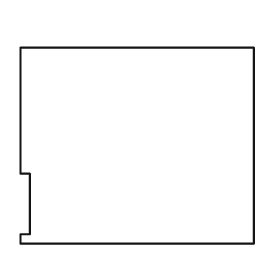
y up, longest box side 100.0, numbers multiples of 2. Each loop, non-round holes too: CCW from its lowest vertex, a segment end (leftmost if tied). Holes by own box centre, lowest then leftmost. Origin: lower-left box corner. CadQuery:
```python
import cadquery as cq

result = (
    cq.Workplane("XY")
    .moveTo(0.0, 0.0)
    .lineTo(100.0, 0.0)
    .lineTo(100.0, 84.0)
    .lineTo(0.0, 84.0)
    .lineTo(0.0, 30.0)
    .lineTo(4.0, 30.0)
    .lineTo(4.0, 4.0)
    .lineTo(0.0, 4.0)
    .close()
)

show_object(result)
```